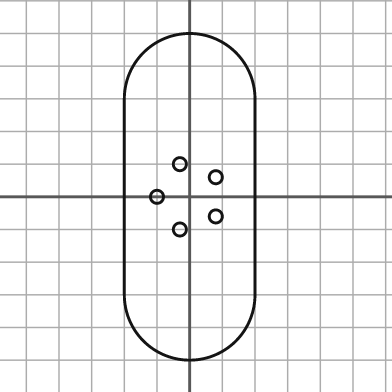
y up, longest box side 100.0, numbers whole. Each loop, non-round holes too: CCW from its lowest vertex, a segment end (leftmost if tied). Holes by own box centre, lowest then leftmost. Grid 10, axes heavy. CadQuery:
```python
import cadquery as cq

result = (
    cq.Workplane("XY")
    .moveTo(-20.0, -30.0)
    .threePointArc((0.0, -50.0), (20.0, -30.0))
    .lineTo(20.0, 30.0)
    .threePointArc((0.0, 50.0), (-20.0, 30.0))
    .close()
    .moveTo(-3.0, -10.0)
    .circle(2.0)
    .moveTo(8.0, -6.0)
    .circle(2.0)
    .moveTo(-10.0, 0.0)
    .circle(2.0)
    .moveTo(8.0, 6.0)
    .circle(2.0)
    .moveTo(-3.0, 10.0)
    .circle(2.0)
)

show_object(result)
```